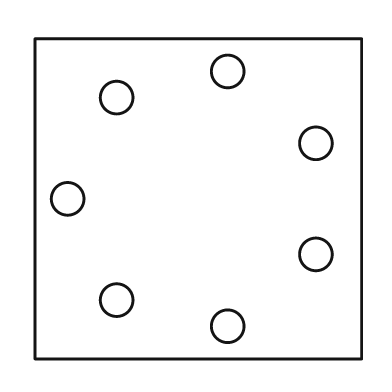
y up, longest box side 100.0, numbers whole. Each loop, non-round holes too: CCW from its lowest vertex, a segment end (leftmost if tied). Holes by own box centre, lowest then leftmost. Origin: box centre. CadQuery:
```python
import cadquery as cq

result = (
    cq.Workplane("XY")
    .moveTo(-50.0, -49.0)
    .lineTo(50.0, -49.0)
    .lineTo(50.0, 49.0)
    .lineTo(-50.0, 49.0)
    .close()
    .moveTo(9.0, -39.0)
    .circle(5.0)
    .moveTo(-25.0, -31.0)
    .circle(5.0)
    .moveTo(36.0, -17.0)
    .circle(5.0)
    .moveTo(-40.0, 0.0)
    .circle(5.0)
    .moveTo(36.0, 17.0)
    .circle(5.0)
    .moveTo(-25.0, 31.0)
    .circle(5.0)
    .moveTo(9.0, 39.0)
    .circle(5.0)
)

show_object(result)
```